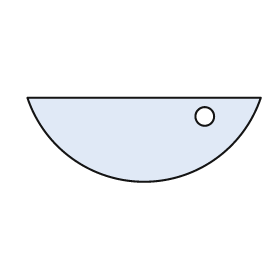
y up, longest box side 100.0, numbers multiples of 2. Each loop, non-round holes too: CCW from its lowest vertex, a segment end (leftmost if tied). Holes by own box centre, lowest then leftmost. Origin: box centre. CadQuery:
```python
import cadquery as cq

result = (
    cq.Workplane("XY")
    .moveTo(-50.0, 18.0)
    .threePointArc((0.0, -18.0), (50.0, 18.0))
    .close()
    .moveTo(26.0, 10.0)
    .circle(4.0)
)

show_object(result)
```